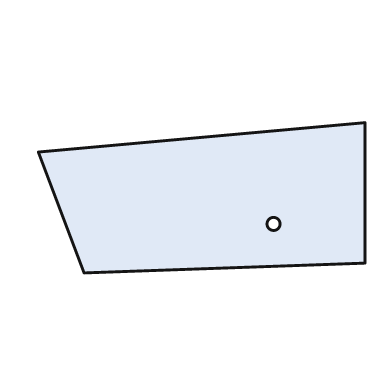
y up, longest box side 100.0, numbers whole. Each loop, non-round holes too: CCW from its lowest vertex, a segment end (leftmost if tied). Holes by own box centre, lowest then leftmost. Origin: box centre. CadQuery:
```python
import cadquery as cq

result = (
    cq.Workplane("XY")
    .moveTo(-36.0, -23.0)
    .lineTo(50.0, -20.0)
    .lineTo(50.0, 23.0)
    .lineTo(-50.0, 14.0)
    .close()
    .moveTo(22.0, -8.0)
    .circle(2.0)
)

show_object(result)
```